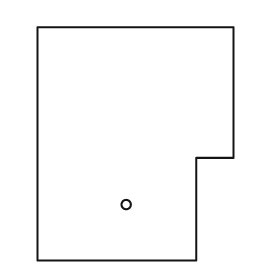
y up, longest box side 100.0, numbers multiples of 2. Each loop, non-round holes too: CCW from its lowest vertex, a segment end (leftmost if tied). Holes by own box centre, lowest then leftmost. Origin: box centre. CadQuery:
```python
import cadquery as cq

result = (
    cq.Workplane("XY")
    .moveTo(-42.0, -50.0)
    .lineTo(26.0, -50.0)
    .lineTo(26.0, -6.0)
    .lineTo(42.0, -6.0)
    .lineTo(42.0, 50.0)
    .lineTo(-42.0, 50.0)
    .close()
    .moveTo(-4.0, -26.0)
    .circle(2.0)
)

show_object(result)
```